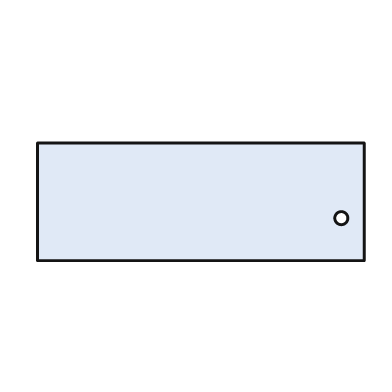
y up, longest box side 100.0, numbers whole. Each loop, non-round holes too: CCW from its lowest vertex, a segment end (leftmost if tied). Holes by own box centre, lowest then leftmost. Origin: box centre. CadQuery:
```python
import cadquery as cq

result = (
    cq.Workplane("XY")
    .moveTo(-50.0, -18.0)
    .lineTo(50.0, -18.0)
    .lineTo(50.0, 18.0)
    .lineTo(-50.0, 18.0)
    .close()
    .moveTo(43.0, -5.0)
    .circle(2.0)
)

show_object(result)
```